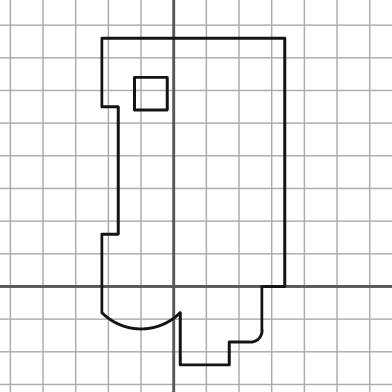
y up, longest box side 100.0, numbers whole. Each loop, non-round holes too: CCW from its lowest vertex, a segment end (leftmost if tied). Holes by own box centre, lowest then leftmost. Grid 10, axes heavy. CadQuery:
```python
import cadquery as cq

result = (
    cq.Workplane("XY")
    .moveTo(2.0, -24.0)
    .lineTo(17.0, -24.0)
    .lineTo(17.0, -17.0)
    .lineTo(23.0, -17.0)
    .threePointArc((26.0, -16.0), (27.0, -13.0))
    .lineTo(27.0, 0.0)
    .lineTo(34.0, 0.0)
    .lineTo(34.0, 76.0)
    .lineTo(-22.0, 76.0)
    .lineTo(-22.0, 55.0)
    .lineTo(-17.0, 55.0)
    .lineTo(-17.0, 16.0)
    .lineTo(-22.0, 16.0)
    .lineTo(-22.0, -8.0)
    .threePointArc((-10.0, -13.0), (2.0, -8.0))
    .close()
    .moveTo(-12.0, 54.0)
    .lineTo(-2.0, 54.0)
    .lineTo(-2.0, 64.0)
    .lineTo(-12.0, 64.0)
    .close()
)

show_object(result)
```